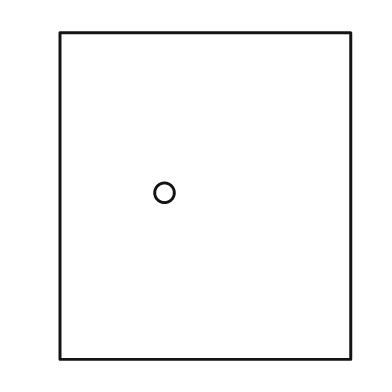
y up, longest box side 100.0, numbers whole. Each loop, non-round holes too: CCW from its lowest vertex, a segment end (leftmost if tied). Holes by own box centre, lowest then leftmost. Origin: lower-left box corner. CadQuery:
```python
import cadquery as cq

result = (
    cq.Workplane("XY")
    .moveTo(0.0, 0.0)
    .lineTo(89.0, 0.0)
    .lineTo(89.0, 100.0)
    .lineTo(0.0, 100.0)
    .close()
    .moveTo(32.0, 51.0)
    .circle(3.0)
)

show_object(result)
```